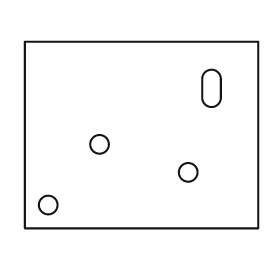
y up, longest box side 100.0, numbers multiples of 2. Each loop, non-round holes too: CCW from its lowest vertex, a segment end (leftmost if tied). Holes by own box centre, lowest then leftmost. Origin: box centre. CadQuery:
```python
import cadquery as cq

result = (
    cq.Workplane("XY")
    .moveTo(-50.0, -40.0)
    .lineTo(50.0, -40.0)
    .lineTo(50.0, 40.0)
    .lineTo(-50.0, 40.0)
    .close()
    .moveTo(-40.0, -30.0)
    .circle(4.0)
    .moveTo(20.0, -16.0)
    .circle(4.0)
    .moveTo(-18.0, -4.0)
    .circle(4.0)
    .moveTo(26.0, 16.0)
    .threePointArc((30.0, 12.0), (34.0, 16.0))
    .lineTo(34.0, 24.0)
    .threePointArc((30.0, 28.0), (26.0, 24.0))
    .close()
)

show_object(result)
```